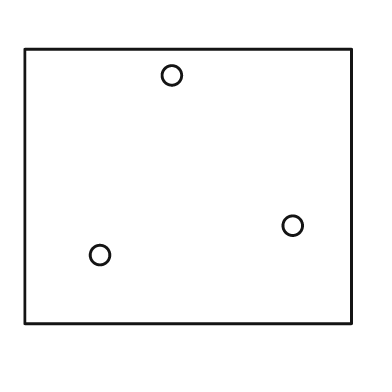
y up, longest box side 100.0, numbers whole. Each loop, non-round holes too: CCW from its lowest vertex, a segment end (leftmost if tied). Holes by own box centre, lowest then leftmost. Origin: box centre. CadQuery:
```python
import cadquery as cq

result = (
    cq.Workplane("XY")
    .moveTo(-50.0, -42.0)
    .lineTo(50.0, -42.0)
    .lineTo(50.0, 42.0)
    .lineTo(-50.0, 42.0)
    .close()
    .moveTo(-27.0, -21.0)
    .circle(3.0)
    .moveTo(32.0, -12.0)
    .circle(3.0)
    .moveTo(-5.0, 34.0)
    .circle(3.0)
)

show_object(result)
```